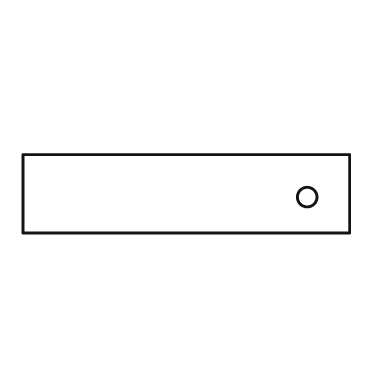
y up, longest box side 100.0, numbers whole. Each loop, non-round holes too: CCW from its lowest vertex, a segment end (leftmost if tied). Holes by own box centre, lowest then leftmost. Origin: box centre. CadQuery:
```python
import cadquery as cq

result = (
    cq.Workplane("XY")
    .moveTo(-50.0, -12.0)
    .lineTo(50.0, -12.0)
    .lineTo(50.0, 12.0)
    .lineTo(-50.0, 12.0)
    .close()
    .moveTo(37.0, -1.0)
    .circle(3.0)
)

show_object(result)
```